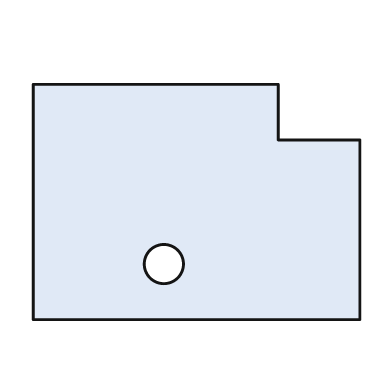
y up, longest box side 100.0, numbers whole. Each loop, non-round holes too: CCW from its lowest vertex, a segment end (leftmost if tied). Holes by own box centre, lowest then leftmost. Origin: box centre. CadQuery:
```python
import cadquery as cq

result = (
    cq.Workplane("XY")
    .moveTo(-50.0, -36.0)
    .lineTo(50.0, -36.0)
    .lineTo(50.0, 19.0)
    .lineTo(25.0, 19.0)
    .lineTo(25.0, 36.0)
    .lineTo(-50.0, 36.0)
    .close()
    .moveTo(-10.0, -19.0)
    .circle(6.0)
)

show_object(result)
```